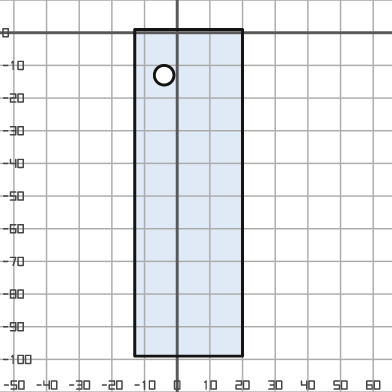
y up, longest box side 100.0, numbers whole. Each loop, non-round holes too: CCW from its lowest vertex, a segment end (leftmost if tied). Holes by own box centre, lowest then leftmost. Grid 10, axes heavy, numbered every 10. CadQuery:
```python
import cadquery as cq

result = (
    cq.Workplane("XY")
    .moveTo(-13.0, -99.0)
    .lineTo(20.0, -99.0)
    .lineTo(20.0, 1.0)
    .lineTo(-13.0, 1.0)
    .close()
    .moveTo(-4.0, -13.0)
    .circle(3.0)
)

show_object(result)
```